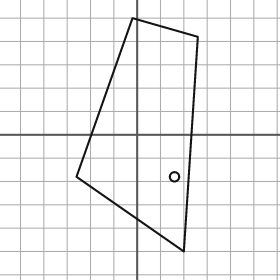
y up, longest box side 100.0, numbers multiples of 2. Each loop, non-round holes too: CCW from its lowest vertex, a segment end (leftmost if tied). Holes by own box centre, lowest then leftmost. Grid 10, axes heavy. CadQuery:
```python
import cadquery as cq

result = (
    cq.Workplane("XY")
    .moveTo(20.0, -50.0)
    .lineTo(26.0, 42.0)
    .lineTo(-2.0, 50.0)
    .lineTo(-26.0, -18.0)
    .close()
    .moveTo(16.0, -18.0)
    .circle(2.0)
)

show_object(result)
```